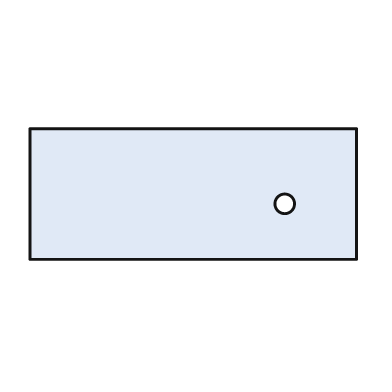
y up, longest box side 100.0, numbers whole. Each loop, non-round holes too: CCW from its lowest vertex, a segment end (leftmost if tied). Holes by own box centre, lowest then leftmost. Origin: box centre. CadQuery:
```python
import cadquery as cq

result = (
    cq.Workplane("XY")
    .moveTo(-50.0, -20.0)
    .lineTo(50.0, -20.0)
    .lineTo(50.0, 20.0)
    .lineTo(-50.0, 20.0)
    .close()
    .moveTo(28.0, -3.0)
    .circle(3.0)
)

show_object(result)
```